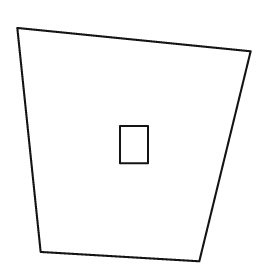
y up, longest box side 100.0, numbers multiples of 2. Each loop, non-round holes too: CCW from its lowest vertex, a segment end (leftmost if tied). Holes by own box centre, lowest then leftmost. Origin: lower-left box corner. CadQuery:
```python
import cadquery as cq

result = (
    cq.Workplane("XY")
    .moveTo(78.0, 0.0)
    .lineTo(100.0, 90.0)
    .lineTo(0.0, 100.0)
    .lineTo(10.0, 4.0)
    .close()
    .moveTo(44.0, 42.0)
    .lineTo(56.0, 42.0)
    .lineTo(56.0, 58.0)
    .lineTo(44.0, 58.0)
    .close()
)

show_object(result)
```